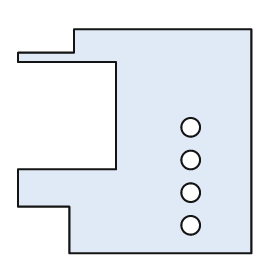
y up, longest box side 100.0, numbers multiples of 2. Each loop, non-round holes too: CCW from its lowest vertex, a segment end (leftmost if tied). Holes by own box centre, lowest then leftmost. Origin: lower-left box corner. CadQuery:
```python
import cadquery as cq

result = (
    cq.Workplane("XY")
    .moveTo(22.0, 0.0)
    .lineTo(100.0, 0.0)
    .lineTo(100.0, 96.0)
    .lineTo(24.0, 96.0)
    .lineTo(24.0, 86.0)
    .lineTo(0.0, 86.0)
    .lineTo(0.0, 82.0)
    .lineTo(42.0, 82.0)
    .lineTo(42.0, 36.0)
    .lineTo(0.0, 36.0)
    .lineTo(0.0, 20.0)
    .lineTo(22.0, 20.0)
    .close()
    .moveTo(74.0, 12.0)
    .circle(4.0)
    .moveTo(74.0, 26.0)
    .circle(4.0)
    .moveTo(74.0, 40.0)
    .circle(4.0)
    .moveTo(74.0, 54.0)
    .circle(4.0)
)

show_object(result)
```